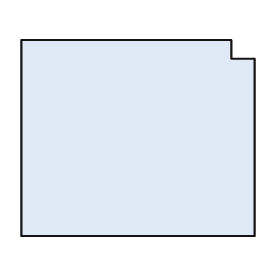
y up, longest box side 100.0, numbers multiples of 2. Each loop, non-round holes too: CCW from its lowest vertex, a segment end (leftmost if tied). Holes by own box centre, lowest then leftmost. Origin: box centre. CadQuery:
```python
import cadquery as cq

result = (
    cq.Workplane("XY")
    .moveTo(-50.0, -42.0)
    .lineTo(50.0, -42.0)
    .lineTo(50.0, 34.0)
    .lineTo(40.0, 34.0)
    .lineTo(40.0, 42.0)
    .lineTo(-50.0, 42.0)
    .close()
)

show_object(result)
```